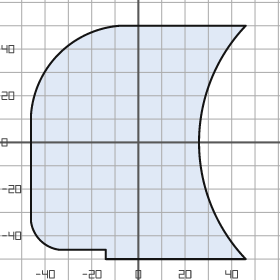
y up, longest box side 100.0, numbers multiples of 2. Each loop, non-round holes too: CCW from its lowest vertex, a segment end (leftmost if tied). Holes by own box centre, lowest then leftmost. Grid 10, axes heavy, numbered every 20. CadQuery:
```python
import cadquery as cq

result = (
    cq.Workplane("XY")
    .moveTo(-14.0, -50.0)
    .lineTo(46.0, -50.0)
    .threePointArc((26.0, 0.0), (46.0, 50.0))
    .lineTo(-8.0, 50.0)
    .threePointArc((-34.0, 38.0), (-46.0, 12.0))
    .lineTo(-46.0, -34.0)
    .threePointArc((-42.0, -42.0), (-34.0, -46.0))
    .lineTo(-14.0, -46.0)
    .close()
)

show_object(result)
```